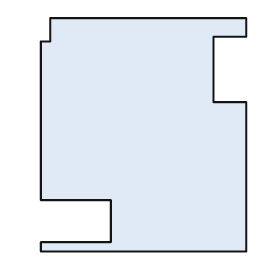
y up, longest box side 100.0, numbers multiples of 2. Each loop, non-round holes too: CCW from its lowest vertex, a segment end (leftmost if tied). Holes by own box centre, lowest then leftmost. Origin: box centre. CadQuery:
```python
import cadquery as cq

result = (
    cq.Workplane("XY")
    .moveTo(-44.0, -50.0)
    .lineTo(44.0, -50.0)
    .lineTo(44.0, 14.0)
    .lineTo(30.0, 14.0)
    .lineTo(30.0, 42.0)
    .lineTo(44.0, 42.0)
    .lineTo(44.0, 50.0)
    .lineTo(-40.0, 50.0)
    .lineTo(-40.0, 40.0)
    .lineTo(-44.0, 40.0)
    .lineTo(-44.0, -28.0)
    .lineTo(-14.0, -28.0)
    .lineTo(-14.0, -46.0)
    .lineTo(-44.0, -46.0)
    .close()
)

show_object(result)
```